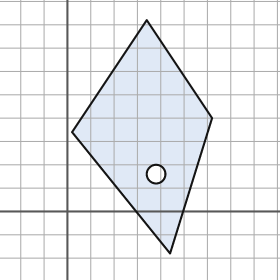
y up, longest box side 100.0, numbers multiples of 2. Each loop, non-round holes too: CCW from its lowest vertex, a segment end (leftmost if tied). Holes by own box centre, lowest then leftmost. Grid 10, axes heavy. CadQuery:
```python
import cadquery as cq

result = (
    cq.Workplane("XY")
    .moveTo(44.0, -18.0)
    .lineTo(62.0, 40.0)
    .lineTo(34.0, 82.0)
    .lineTo(2.0, 34.0)
    .close()
    .moveTo(38.0, 16.0)
    .circle(4.0)
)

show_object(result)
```